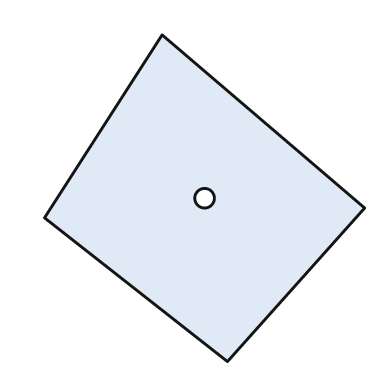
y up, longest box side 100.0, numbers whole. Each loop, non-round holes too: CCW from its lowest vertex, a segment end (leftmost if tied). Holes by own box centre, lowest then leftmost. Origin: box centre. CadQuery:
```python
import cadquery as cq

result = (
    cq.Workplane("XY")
    .moveTo(7.0, -50.0)
    .lineTo(49.0, -3.0)
    .lineTo(-13.0, 50.0)
    .lineTo(-49.0, -6.0)
    .close()
    .moveTo(0.0, 0.0)
    .circle(3.0)
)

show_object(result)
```